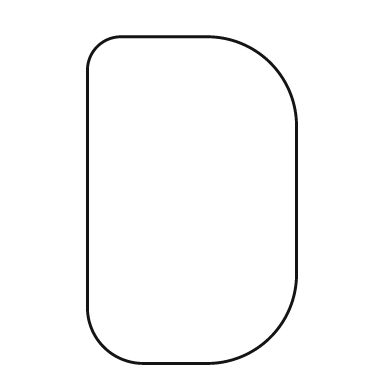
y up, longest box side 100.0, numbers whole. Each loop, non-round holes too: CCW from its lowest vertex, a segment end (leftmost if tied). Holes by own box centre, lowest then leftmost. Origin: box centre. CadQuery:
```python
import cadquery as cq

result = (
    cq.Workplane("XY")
    .moveTo(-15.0, -50.0)
    .lineTo(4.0, -50.0)
    .threePointArc((24.0, -42.0), (32.0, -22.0))
    .lineTo(32.0, 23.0)
    .threePointArc((24.0, 42.0), (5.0, 50.0))
    .lineTo(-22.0, 50.0)
    .threePointArc((-29.0, 47.0), (-32.0, 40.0))
    .lineTo(-32.0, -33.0)
    .threePointArc((-27.0, -45.0), (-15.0, -50.0))
    .close()
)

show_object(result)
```